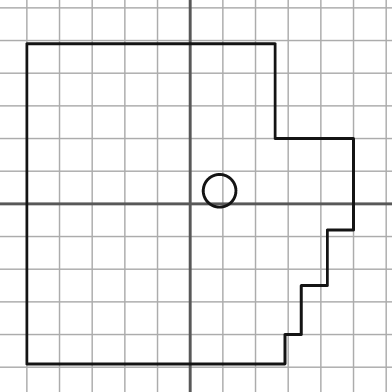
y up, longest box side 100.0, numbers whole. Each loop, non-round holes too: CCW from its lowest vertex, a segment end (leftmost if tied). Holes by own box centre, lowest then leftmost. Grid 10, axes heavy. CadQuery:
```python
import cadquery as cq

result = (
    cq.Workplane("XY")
    .moveTo(-50.0, -49.0)
    .lineTo(29.0, -49.0)
    .lineTo(29.0, -40.0)
    .lineTo(34.0, -40.0)
    .lineTo(34.0, -25.0)
    .lineTo(42.0, -25.0)
    .lineTo(42.0, -8.0)
    .lineTo(50.0, -8.0)
    .lineTo(50.0, 20.0)
    .lineTo(26.0, 20.0)
    .lineTo(26.0, 49.0)
    .lineTo(-50.0, 49.0)
    .close()
    .moveTo(9.0, 4.0)
    .circle(5.0)
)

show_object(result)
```